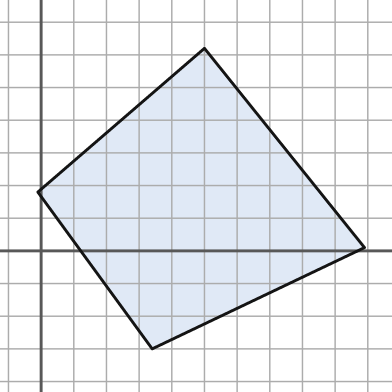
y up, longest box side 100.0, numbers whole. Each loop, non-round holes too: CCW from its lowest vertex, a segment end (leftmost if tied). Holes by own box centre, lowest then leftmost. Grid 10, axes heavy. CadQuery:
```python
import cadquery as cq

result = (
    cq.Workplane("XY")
    .moveTo(34.0, -30.0)
    .lineTo(99.0, 1.0)
    .lineTo(50.0, 62.0)
    .lineTo(-1.0, 18.0)
    .close()
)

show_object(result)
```